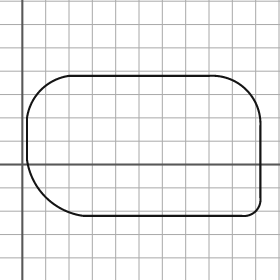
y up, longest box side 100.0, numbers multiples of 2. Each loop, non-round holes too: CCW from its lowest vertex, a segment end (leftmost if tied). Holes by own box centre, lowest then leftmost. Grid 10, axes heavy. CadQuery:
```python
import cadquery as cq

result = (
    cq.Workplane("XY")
    .moveTo(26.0, -22.0)
    .lineTo(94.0, -22.0)
    .threePointArc((100.0, -20.0), (102.0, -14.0))
    .lineTo(102.0, 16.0)
    .threePointArc((96.0, 32.0), (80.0, 38.0))
    .lineTo(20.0, 38.0)
    .threePointArc((8.0, 32.0), (2.0, 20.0))
    .lineTo(2.0, 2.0)
    .threePointArc((10.0, -14.0), (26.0, -22.0))
    .close()
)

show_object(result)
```